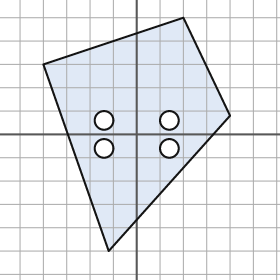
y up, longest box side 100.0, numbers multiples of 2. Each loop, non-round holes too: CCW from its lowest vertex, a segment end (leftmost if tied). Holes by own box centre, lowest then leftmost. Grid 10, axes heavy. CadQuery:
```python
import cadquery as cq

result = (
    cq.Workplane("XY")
    .moveTo(-12.0, -50.0)
    .lineTo(40.0, 8.0)
    .lineTo(20.0, 50.0)
    .lineTo(-40.0, 30.0)
    .close()
    .moveTo(-14.0, -6.0)
    .circle(4.0)
    .moveTo(14.0, -6.0)
    .circle(4.0)
    .moveTo(-14.0, 6.0)
    .circle(4.0)
    .moveTo(14.0, 6.0)
    .circle(4.0)
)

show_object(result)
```